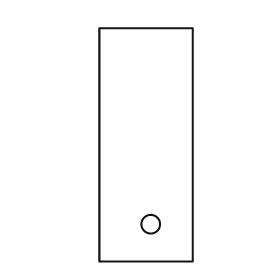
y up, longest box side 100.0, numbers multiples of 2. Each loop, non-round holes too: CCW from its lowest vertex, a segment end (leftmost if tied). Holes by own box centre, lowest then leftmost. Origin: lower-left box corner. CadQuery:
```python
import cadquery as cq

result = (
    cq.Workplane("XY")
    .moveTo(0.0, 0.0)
    .lineTo(40.0, 0.0)
    .lineTo(40.0, 100.0)
    .lineTo(0.0, 100.0)
    .close()
    .moveTo(22.0, 16.0)
    .circle(4.0)
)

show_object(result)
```